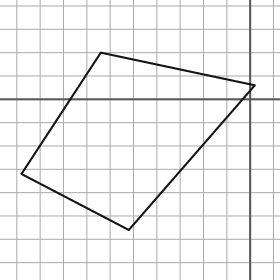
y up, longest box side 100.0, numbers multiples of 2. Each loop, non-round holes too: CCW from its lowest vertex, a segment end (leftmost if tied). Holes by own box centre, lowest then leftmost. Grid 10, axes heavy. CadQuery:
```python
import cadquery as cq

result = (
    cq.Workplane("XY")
    .moveTo(-52.0, -56.0)
    .lineTo(2.0, 6.0)
    .lineTo(-64.0, 20.0)
    .lineTo(-98.0, -32.0)
    .close()
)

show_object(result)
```